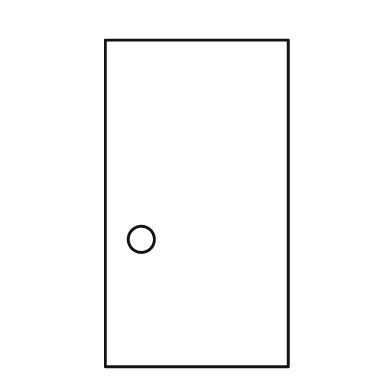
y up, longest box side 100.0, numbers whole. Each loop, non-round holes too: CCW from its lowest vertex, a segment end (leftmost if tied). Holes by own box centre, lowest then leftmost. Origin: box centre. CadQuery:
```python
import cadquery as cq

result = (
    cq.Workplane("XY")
    .moveTo(-28.0, -50.0)
    .lineTo(28.0, -50.0)
    .lineTo(28.0, 50.0)
    .lineTo(-28.0, 50.0)
    .close()
    .moveTo(-17.0, -11.0)
    .circle(4.0)
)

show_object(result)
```